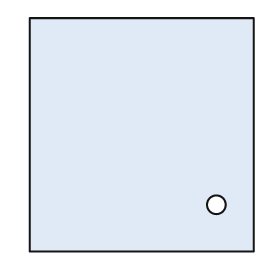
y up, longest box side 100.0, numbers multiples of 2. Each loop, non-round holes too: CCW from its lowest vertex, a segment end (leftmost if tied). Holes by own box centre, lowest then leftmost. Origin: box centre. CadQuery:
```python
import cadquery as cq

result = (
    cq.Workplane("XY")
    .moveTo(-48.0, -50.0)
    .lineTo(48.0, -50.0)
    .lineTo(48.0, 50.0)
    .lineTo(-48.0, 50.0)
    .close()
    .moveTo(32.0, -30.0)
    .circle(4.0)
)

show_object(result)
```